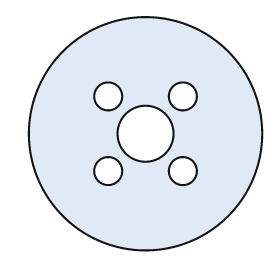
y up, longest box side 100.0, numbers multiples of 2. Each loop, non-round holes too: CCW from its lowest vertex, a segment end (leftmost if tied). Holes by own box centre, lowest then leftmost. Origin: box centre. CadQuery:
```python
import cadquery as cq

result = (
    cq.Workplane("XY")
    .moveTo(0.0, 0.0)
    .circle(50.0)
    .moveTo(-16.0, -16.0)
    .circle(6.0)
    .moveTo(16.0, -16.0)
    .circle(6.0)
    .moveTo(0.0, 0.0)
    .circle(12.0)
    .moveTo(-16.0, 16.0)
    .circle(6.0)
    .moveTo(16.0, 16.0)
    .circle(6.0)
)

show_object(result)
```